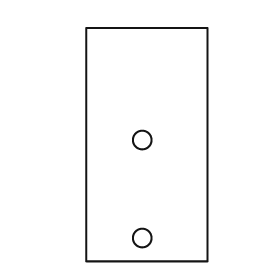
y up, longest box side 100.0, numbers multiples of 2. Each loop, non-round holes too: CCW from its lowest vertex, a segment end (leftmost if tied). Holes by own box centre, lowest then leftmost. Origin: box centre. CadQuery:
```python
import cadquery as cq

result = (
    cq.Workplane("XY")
    .moveTo(-26.0, -50.0)
    .lineTo(26.0, -50.0)
    .lineTo(26.0, 50.0)
    .lineTo(-26.0, 50.0)
    .close()
    .moveTo(-2.0, -40.0)
    .circle(4.0)
    .moveTo(-2.0, 2.0)
    .circle(4.0)
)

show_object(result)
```